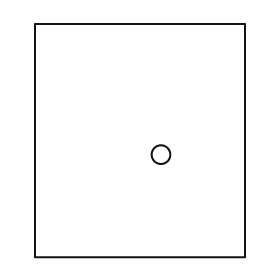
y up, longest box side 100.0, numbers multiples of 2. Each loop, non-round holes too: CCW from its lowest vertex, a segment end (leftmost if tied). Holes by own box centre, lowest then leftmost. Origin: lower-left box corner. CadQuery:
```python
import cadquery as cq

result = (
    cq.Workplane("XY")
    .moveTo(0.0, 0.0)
    .lineTo(90.0, 0.0)
    .lineTo(90.0, 100.0)
    .lineTo(0.0, 100.0)
    .close()
    .moveTo(54.0, 44.0)
    .circle(4.0)
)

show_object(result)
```